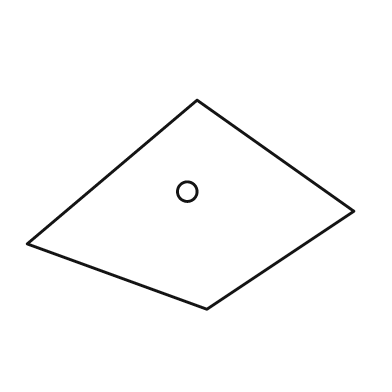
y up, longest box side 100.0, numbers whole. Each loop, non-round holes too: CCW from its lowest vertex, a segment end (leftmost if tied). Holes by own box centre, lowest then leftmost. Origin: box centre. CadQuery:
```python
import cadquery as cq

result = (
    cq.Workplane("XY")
    .moveTo(5.0, -32.0)
    .lineTo(50.0, -2.0)
    .lineTo(2.0, 32.0)
    .lineTo(-50.0, -12.0)
    .close()
    .moveTo(-1.0, 4.0)
    .circle(3.0)
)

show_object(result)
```